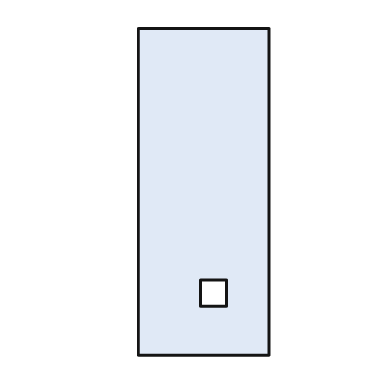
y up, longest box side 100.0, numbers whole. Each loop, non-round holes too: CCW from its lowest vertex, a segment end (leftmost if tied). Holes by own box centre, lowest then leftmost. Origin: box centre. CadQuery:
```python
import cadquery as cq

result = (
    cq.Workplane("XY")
    .moveTo(-20.0, -50.0)
    .lineTo(20.0, -50.0)
    .lineTo(20.0, 50.0)
    .lineTo(-20.0, 50.0)
    .close()
    .moveTo(-1.0, -35.0)
    .lineTo(7.0, -35.0)
    .lineTo(7.0, -27.0)
    .lineTo(-1.0, -27.0)
    .close()
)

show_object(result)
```